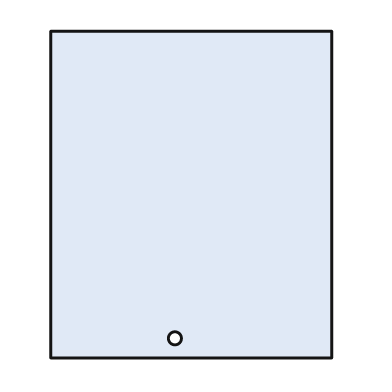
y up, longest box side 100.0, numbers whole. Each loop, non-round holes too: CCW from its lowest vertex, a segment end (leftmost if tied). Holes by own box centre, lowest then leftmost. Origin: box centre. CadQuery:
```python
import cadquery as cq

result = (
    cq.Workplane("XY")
    .moveTo(-43.0, -50.0)
    .lineTo(43.0, -50.0)
    .lineTo(43.0, 50.0)
    .lineTo(-43.0, 50.0)
    .close()
    .moveTo(-5.0, -44.0)
    .circle(2.0)
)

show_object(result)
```